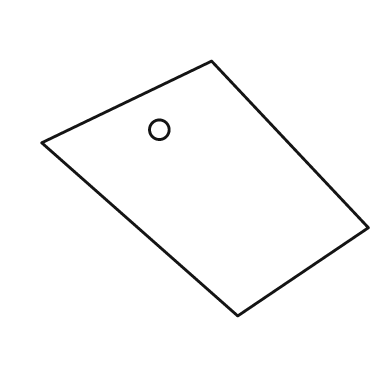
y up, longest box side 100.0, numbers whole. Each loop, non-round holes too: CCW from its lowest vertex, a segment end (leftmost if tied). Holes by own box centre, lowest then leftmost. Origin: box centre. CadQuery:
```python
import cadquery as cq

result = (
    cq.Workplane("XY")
    .moveTo(10.0, -39.0)
    .lineTo(50.0, -12.0)
    .lineTo(2.0, 39.0)
    .lineTo(-50.0, 14.0)
    .close()
    .moveTo(-14.0, 18.0)
    .circle(3.0)
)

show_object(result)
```